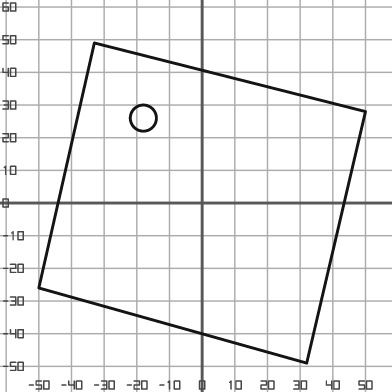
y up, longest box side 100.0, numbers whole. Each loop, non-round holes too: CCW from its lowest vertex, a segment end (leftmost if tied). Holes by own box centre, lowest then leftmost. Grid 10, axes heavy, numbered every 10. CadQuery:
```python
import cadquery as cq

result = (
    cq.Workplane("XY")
    .moveTo(32.0, -49.0)
    .lineTo(50.0, 28.0)
    .lineTo(-33.0, 49.0)
    .lineTo(-50.0, -26.0)
    .close()
    .moveTo(-18.0, 26.0)
    .circle(4.0)
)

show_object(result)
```